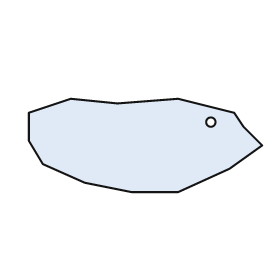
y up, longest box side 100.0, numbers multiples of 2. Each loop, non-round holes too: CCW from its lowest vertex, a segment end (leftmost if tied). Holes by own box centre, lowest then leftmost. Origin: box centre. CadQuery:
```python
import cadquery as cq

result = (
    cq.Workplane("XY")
    .moveTo(-6.0, -20.0)
    .lineTo(14.0, -20.0)
    .lineTo(36.0, -10.0)
    .lineTo(50.0, 0.0)
    .lineTo(42.0, 8.0)
    .lineTo(38.0, 14.0)
    .lineTo(14.0, 20.0)
    .lineTo(-12.0, 18.0)
    .lineTo(-32.0, 20.0)
    .lineTo(-50.0, 14.0)
    .lineTo(-50.0, 2.0)
    .lineTo(-44.0, -8.0)
    .lineTo(-26.0, -16.0)
    .close()
    .moveTo(28.0, 10.0)
    .circle(2.0)
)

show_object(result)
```